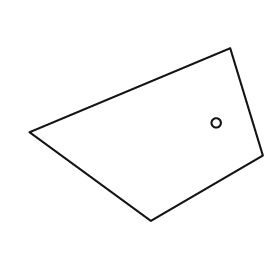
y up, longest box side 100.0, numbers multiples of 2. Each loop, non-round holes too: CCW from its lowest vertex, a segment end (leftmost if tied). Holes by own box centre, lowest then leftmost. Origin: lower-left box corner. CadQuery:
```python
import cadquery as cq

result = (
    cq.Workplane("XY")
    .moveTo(52.0, 0.0)
    .lineTo(100.0, 28.0)
    .lineTo(86.0, 74.0)
    .lineTo(0.0, 38.0)
    .close()
    .moveTo(80.0, 42.0)
    .circle(2.0)
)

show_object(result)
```